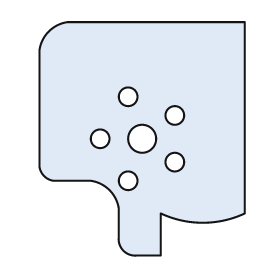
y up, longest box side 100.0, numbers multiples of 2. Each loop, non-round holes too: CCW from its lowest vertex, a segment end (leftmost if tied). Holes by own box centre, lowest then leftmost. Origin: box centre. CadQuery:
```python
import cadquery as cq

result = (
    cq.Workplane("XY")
    .moveTo(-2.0, -50.0)
    .lineTo(8.0, -50.0)
    .lineTo(8.0, -32.0)
    .threePointArc((26.0, -36.0), (44.0, -32.0))
    .lineTo(44.0, 50.0)
    .lineTo(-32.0, 50.0)
    .threePointArc((-40.0, 46.0), (-44.0, 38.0))
    .lineTo(-44.0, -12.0)
    .threePointArc((-42.0, -16.0), (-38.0, -18.0))
    .lineTo(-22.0, -18.0)
    .threePointArc((-14.0, -22.0), (-10.0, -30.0))
    .lineTo(-10.0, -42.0)
    .threePointArc((-8.0, -48.0), (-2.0, -50.0))
    .close()
    .moveTo(-6.0, -18.0)
    .circle(4.0)
    .moveTo(14.0, -10.0)
    .circle(4.0)
    .moveTo(-18.0, 0.0)
    .circle(4.0)
    .moveTo(0.0, 0.0)
    .circle(6.0)
    .moveTo(14.0, 10.0)
    .circle(4.0)
    .moveTo(-6.0, 18.0)
    .circle(4.0)
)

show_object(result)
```